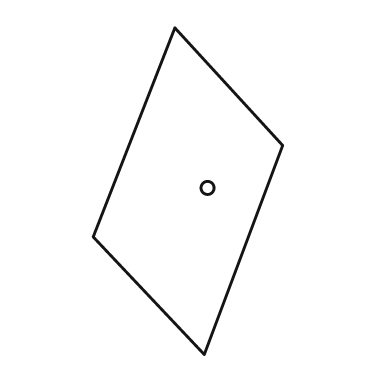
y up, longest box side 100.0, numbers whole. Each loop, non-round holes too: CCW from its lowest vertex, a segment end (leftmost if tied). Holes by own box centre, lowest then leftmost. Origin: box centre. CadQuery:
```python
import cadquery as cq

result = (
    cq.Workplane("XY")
    .moveTo(5.0, -50.0)
    .lineTo(29.0, 14.0)
    .lineTo(-4.0, 50.0)
    .lineTo(-29.0, -14.0)
    .close()
    .moveTo(6.0, 1.0)
    .circle(2.0)
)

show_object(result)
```